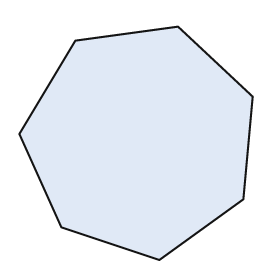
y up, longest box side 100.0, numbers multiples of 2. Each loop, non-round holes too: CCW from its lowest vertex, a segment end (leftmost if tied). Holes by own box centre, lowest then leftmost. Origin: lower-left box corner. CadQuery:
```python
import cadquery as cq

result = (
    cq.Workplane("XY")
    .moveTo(60.0, 0.0)
    .lineTo(96.0, 26.0)
    .lineTo(100.0, 70.0)
    .lineTo(68.0, 100.0)
    .lineTo(24.0, 94.0)
    .lineTo(0.0, 54.0)
    .lineTo(18.0, 14.0)
    .close()
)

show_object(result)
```